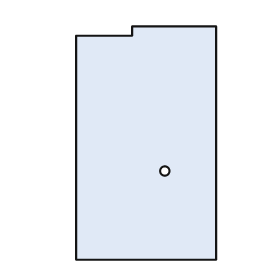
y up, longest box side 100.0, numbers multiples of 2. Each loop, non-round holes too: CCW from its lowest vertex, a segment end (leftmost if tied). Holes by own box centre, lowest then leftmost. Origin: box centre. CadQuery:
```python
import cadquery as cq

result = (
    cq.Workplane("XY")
    .moveTo(-30.0, -50.0)
    .lineTo(30.0, -50.0)
    .lineTo(30.0, 50.0)
    .lineTo(-6.0, 50.0)
    .lineTo(-6.0, 46.0)
    .lineTo(-30.0, 46.0)
    .close()
    .moveTo(8.0, -12.0)
    .circle(2.0)
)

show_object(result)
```